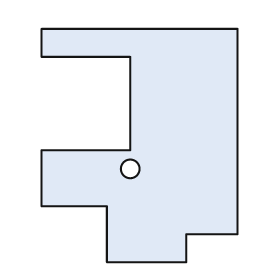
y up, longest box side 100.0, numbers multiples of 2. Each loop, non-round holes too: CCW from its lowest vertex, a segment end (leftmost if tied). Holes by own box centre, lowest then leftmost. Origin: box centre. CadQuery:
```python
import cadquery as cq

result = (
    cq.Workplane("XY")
    .moveTo(-14.0, -50.0)
    .lineTo(20.0, -50.0)
    .lineTo(20.0, -38.0)
    .lineTo(42.0, -38.0)
    .lineTo(42.0, 50.0)
    .lineTo(-42.0, 50.0)
    .lineTo(-42.0, 38.0)
    .lineTo(-4.0, 38.0)
    .lineTo(-4.0, -2.0)
    .lineTo(-42.0, -2.0)
    .lineTo(-42.0, -26.0)
    .lineTo(-14.0, -26.0)
    .close()
    .moveTo(-4.0, -10.0)
    .circle(4.0)
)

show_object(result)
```